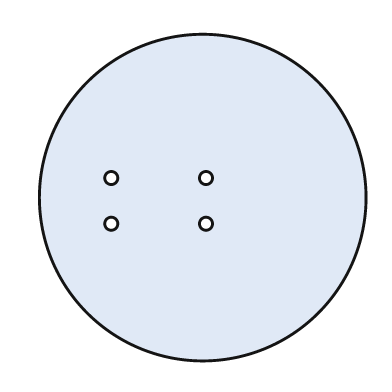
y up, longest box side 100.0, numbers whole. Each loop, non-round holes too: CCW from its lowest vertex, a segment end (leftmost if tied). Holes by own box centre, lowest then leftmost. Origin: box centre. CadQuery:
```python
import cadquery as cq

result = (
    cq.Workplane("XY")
    .moveTo(0.0, 0.0)
    .circle(50.0)
    .moveTo(-28.0, -8.0)
    .circle(2.0)
    .moveTo(1.0, -8.0)
    .circle(2.0)
    .moveTo(-28.0, 6.0)
    .circle(2.0)
    .moveTo(1.0, 6.0)
    .circle(2.0)
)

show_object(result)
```